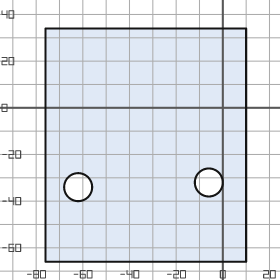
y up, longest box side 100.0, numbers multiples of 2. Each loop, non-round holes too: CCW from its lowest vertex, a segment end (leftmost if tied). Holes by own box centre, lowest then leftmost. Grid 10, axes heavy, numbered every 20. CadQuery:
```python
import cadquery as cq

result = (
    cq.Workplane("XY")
    .moveTo(-76.0, -66.0)
    .lineTo(10.0, -66.0)
    .lineTo(10.0, 34.0)
    .lineTo(-76.0, 34.0)
    .close()
    .moveTo(-62.0, -34.0)
    .circle(6.0)
    .moveTo(-6.0, -32.0)
    .circle(6.0)
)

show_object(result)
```